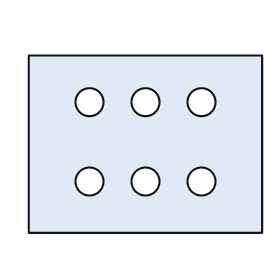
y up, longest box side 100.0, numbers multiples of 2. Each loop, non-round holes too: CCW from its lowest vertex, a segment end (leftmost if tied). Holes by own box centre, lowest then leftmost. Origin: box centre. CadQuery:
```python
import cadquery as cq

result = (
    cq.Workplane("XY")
    .moveTo(-50.0, -38.0)
    .lineTo(50.0, -38.0)
    .lineTo(50.0, 38.0)
    .lineTo(-50.0, 38.0)
    .close()
    .moveTo(-24.0, -16.0)
    .circle(6.0)
    .moveTo(0.0, -16.0)
    .circle(6.0)
    .moveTo(24.0, -16.0)
    .circle(6.0)
    .moveTo(-24.0, 18.0)
    .circle(6.0)
    .moveTo(0.0, 18.0)
    .circle(6.0)
    .moveTo(24.0, 18.0)
    .circle(6.0)
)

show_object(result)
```